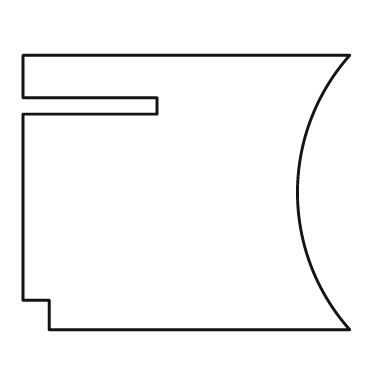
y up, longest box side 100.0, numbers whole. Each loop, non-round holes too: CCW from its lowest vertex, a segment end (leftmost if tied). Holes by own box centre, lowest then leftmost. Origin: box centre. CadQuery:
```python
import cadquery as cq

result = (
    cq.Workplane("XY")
    .moveTo(-42.0, -42.0)
    .lineTo(50.0, -42.0)
    .threePointArc((34.0, 0.0), (50.0, 42.0))
    .lineTo(-50.0, 42.0)
    .lineTo(-50.0, 29.0)
    .lineTo(-9.0, 29.0)
    .lineTo(-9.0, 24.0)
    .lineTo(-50.0, 24.0)
    .lineTo(-50.0, -33.0)
    .lineTo(-42.0, -33.0)
    .close()
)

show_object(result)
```